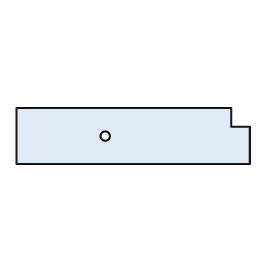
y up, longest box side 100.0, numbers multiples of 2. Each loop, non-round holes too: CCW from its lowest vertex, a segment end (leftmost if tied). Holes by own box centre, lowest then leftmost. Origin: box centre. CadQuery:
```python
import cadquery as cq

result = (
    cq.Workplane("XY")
    .moveTo(-50.0, -12.0)
    .lineTo(50.0, -12.0)
    .lineTo(50.0, 4.0)
    .lineTo(42.0, 4.0)
    .lineTo(42.0, 12.0)
    .lineTo(-50.0, 12.0)
    .close()
    .moveTo(-12.0, 0.0)
    .circle(2.0)
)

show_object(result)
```